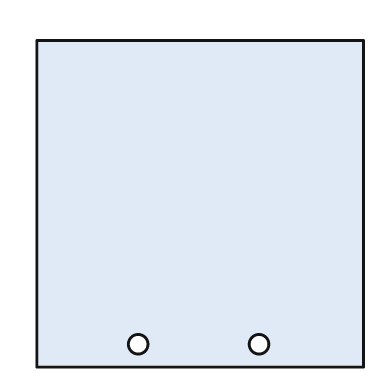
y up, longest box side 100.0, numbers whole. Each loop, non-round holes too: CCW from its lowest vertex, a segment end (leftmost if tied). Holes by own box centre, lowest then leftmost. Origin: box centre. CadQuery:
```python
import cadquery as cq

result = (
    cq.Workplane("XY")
    .moveTo(-50.0, -50.0)
    .lineTo(50.0, -50.0)
    .lineTo(50.0, 50.0)
    .lineTo(-50.0, 50.0)
    .close()
    .moveTo(-19.0, -43.0)
    .circle(3.0)
    .moveTo(18.0, -43.0)
    .circle(3.0)
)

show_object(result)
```